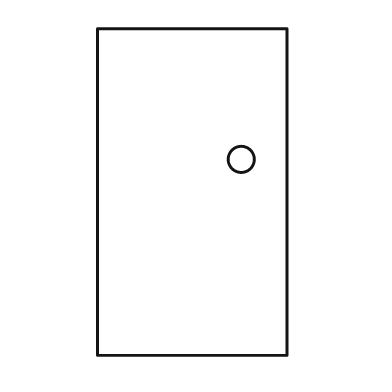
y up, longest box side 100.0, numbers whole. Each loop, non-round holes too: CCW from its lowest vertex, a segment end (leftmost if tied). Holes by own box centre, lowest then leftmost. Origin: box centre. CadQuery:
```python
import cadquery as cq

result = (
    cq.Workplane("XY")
    .moveTo(-29.0, -50.0)
    .lineTo(29.0, -50.0)
    .lineTo(29.0, 50.0)
    .lineTo(-29.0, 50.0)
    .close()
    .moveTo(15.0, 10.0)
    .circle(4.0)
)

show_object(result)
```